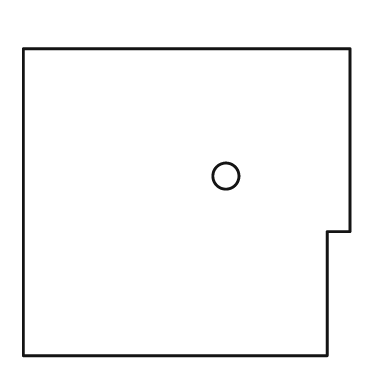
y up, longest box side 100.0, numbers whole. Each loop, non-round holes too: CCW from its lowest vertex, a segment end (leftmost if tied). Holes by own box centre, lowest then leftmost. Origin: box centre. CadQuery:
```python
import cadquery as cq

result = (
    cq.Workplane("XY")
    .moveTo(-50.0, -47.0)
    .lineTo(43.0, -47.0)
    .lineTo(43.0, -9.0)
    .lineTo(50.0, -9.0)
    .lineTo(50.0, 47.0)
    .lineTo(-50.0, 47.0)
    .close()
    .moveTo(12.0, 8.0)
    .circle(4.0)
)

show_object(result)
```